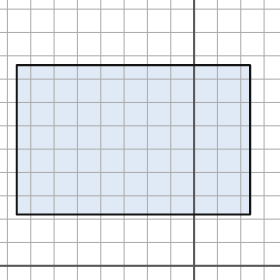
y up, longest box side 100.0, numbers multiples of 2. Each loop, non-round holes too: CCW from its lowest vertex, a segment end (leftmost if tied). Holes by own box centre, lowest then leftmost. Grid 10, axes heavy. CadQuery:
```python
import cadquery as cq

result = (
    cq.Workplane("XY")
    .moveTo(-76.0, 22.0)
    .lineTo(24.0, 22.0)
    .lineTo(24.0, 86.0)
    .lineTo(-76.0, 86.0)
    .close()
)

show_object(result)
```